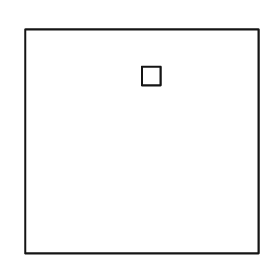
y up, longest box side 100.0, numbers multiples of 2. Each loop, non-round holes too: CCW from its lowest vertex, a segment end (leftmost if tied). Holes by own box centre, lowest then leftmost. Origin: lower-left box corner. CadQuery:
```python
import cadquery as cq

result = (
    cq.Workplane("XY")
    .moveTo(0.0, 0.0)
    .lineTo(100.0, 0.0)
    .lineTo(100.0, 96.0)
    .lineTo(0.0, 96.0)
    .close()
    .moveTo(50.0, 72.0)
    .lineTo(58.0, 72.0)
    .lineTo(58.0, 80.0)
    .lineTo(50.0, 80.0)
    .close()
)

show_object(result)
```